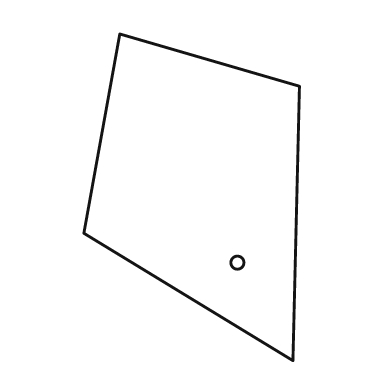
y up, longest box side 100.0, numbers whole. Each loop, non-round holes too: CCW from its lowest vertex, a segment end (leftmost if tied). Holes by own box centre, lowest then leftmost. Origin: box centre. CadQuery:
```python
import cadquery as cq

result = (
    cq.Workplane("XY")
    .moveTo(31.0, -50.0)
    .lineTo(33.0, 34.0)
    .lineTo(-22.0, 50.0)
    .lineTo(-33.0, -11.0)
    .close()
    .moveTo(14.0, -20.0)
    .circle(2.0)
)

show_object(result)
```